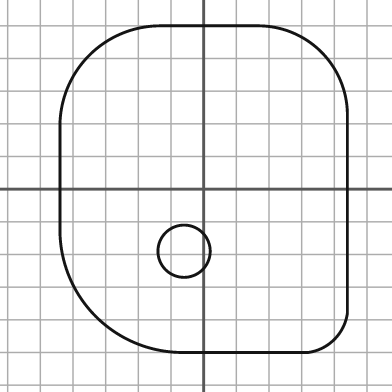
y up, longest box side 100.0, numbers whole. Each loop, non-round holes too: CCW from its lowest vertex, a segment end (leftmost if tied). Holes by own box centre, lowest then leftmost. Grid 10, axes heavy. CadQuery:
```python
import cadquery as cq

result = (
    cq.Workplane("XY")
    .moveTo(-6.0, -50.0)
    .lineTo(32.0, -50.0)
    .threePointArc((40.0, -46.0), (44.0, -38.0))
    .lineTo(44.0, 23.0)
    .threePointArc((36.0, 42.0), (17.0, 50.0))
    .lineTo(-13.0, 50.0)
    .threePointArc((-35.0, 41.0), (-44.0, 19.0))
    .lineTo(-44.0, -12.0)
    .threePointArc((-33.0, -39.0), (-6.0, -50.0))
    .close()
    .moveTo(-6.0, -19.0)
    .circle(8.0)
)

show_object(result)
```